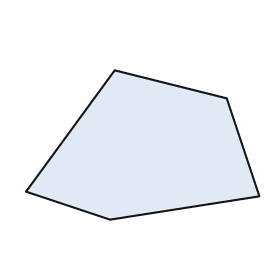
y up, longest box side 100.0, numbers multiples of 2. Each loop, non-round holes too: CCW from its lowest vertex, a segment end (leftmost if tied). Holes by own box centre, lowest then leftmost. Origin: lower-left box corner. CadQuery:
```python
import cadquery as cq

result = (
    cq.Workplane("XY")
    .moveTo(36.0, 0.0)
    .lineTo(100.0, 10.0)
    .lineTo(86.0, 52.0)
    .lineTo(38.0, 64.0)
    .lineTo(0.0, 12.0)
    .close()
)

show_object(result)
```